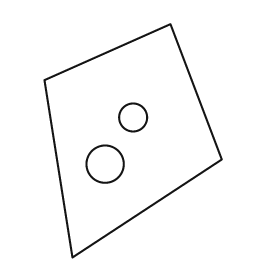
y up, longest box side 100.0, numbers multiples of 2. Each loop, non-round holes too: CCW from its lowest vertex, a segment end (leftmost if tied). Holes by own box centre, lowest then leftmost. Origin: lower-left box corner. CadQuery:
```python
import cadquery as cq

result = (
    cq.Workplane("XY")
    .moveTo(12.0, 0.0)
    .lineTo(76.0, 42.0)
    .lineTo(54.0, 100.0)
    .lineTo(0.0, 76.0)
    .close()
    .moveTo(26.0, 40.0)
    .circle(8.0)
    .moveTo(38.0, 60.0)
    .circle(6.0)
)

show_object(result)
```